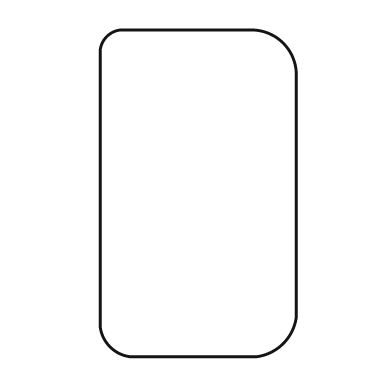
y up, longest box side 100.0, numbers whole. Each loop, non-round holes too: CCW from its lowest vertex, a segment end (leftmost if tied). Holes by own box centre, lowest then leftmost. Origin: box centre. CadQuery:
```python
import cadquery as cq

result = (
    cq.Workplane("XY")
    .moveTo(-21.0, -50.0)
    .lineTo(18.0, -50.0)
    .threePointArc((26.0, -46.0), (30.0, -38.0))
    .lineTo(30.0, 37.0)
    .threePointArc((26.0, 46.0), (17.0, 50.0))
    .lineTo(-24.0, 50.0)
    .threePointArc((-28.0, 48.0), (-30.0, 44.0))
    .lineTo(-30.0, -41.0)
    .threePointArc((-27.0, -47.0), (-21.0, -50.0))
    .close()
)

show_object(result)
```